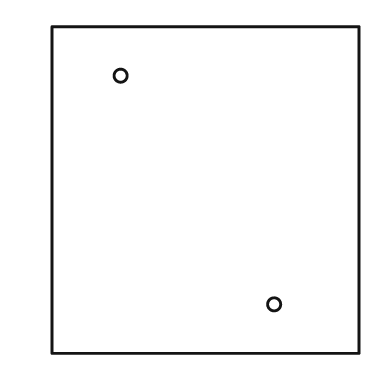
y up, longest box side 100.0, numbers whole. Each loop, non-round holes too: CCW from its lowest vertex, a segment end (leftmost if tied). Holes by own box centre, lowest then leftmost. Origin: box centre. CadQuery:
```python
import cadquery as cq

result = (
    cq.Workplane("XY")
    .moveTo(-47.0, -50.0)
    .lineTo(47.0, -50.0)
    .lineTo(47.0, 50.0)
    .lineTo(-47.0, 50.0)
    .close()
    .moveTo(21.0, -35.0)
    .circle(2.0)
    .moveTo(-26.0, 35.0)
    .circle(2.0)
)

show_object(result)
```